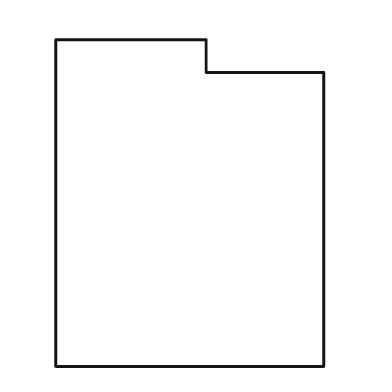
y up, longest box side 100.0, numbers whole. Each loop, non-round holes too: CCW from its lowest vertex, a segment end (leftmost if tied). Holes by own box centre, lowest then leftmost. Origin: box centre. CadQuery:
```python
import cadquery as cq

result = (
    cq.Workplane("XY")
    .moveTo(-41.0, -50.0)
    .lineTo(41.0, -50.0)
    .lineTo(41.0, 40.0)
    .lineTo(5.0, 40.0)
    .lineTo(5.0, 50.0)
    .lineTo(-41.0, 50.0)
    .close()
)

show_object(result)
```